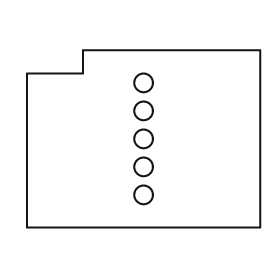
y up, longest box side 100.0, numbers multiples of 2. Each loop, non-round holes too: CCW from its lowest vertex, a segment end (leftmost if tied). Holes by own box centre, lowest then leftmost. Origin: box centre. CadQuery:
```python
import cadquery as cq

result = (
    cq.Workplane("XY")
    .moveTo(-50.0, -38.0)
    .lineTo(50.0, -38.0)
    .lineTo(50.0, 38.0)
    .lineTo(-26.0, 38.0)
    .lineTo(-26.0, 28.0)
    .lineTo(-50.0, 28.0)
    .close()
    .moveTo(0.0, -24.0)
    .circle(4.0)
    .moveTo(0.0, -12.0)
    .circle(4.0)
    .moveTo(0.0, 0.0)
    .circle(4.0)
    .moveTo(0.0, 12.0)
    .circle(4.0)
    .moveTo(0.0, 24.0)
    .circle(4.0)
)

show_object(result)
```